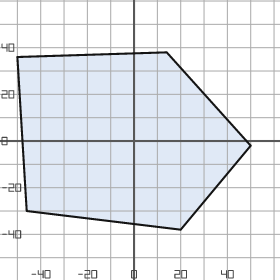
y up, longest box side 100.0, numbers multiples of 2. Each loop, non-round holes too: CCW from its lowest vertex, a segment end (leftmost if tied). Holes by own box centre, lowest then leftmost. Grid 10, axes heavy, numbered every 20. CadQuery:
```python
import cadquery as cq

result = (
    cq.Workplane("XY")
    .moveTo(20.0, -38.0)
    .lineTo(50.0, -2.0)
    .lineTo(14.0, 38.0)
    .lineTo(-50.0, 36.0)
    .lineTo(-46.0, -30.0)
    .close()
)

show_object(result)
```